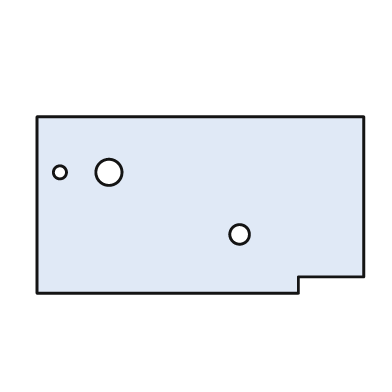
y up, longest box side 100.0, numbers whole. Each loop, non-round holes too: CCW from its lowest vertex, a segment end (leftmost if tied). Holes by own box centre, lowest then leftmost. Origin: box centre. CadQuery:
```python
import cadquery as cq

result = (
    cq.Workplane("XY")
    .moveTo(-50.0, -27.0)
    .lineTo(30.0, -27.0)
    .lineTo(30.0, -22.0)
    .lineTo(50.0, -22.0)
    .lineTo(50.0, 27.0)
    .lineTo(-50.0, 27.0)
    .close()
    .moveTo(12.0, -9.0)
    .circle(3.0)
    .moveTo(-43.0, 10.0)
    .circle(2.0)
    .moveTo(-28.0, 10.0)
    .circle(4.0)
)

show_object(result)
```